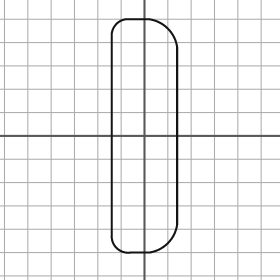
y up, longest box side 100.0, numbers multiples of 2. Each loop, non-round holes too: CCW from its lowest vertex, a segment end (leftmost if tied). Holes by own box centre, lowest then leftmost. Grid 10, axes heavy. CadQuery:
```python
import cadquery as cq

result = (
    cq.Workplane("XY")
    .moveTo(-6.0, -50.0)
    .lineTo(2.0, -50.0)
    .threePointArc((10.0, -46.0), (14.0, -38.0))
    .lineTo(14.0, 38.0)
    .threePointArc((10.0, 46.0), (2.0, 50.0))
    .lineTo(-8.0, 50.0)
    .threePointArc((-12.0, 48.0), (-14.0, 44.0))
    .lineTo(-14.0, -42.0)
    .threePointArc((-12.0, -48.0), (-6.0, -50.0))
    .close()
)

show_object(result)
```